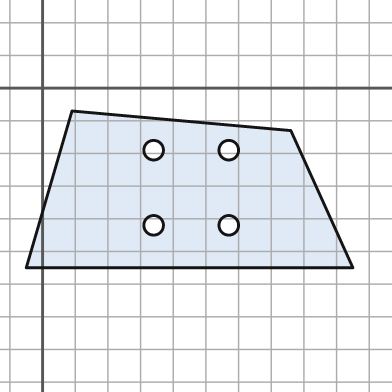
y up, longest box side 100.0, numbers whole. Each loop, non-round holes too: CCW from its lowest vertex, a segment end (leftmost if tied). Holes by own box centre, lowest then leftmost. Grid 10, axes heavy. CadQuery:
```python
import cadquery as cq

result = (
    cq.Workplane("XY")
    .moveTo(-5.0, -55.0)
    .lineTo(95.0, -55.0)
    .lineTo(76.0, -13.0)
    .lineTo(9.0, -7.0)
    .close()
    .moveTo(34.0, -42.0)
    .circle(3.0)
    .moveTo(57.0, -42.0)
    .circle(3.0)
    .moveTo(34.0, -19.0)
    .circle(3.0)
    .moveTo(57.0, -19.0)
    .circle(3.0)
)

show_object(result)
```